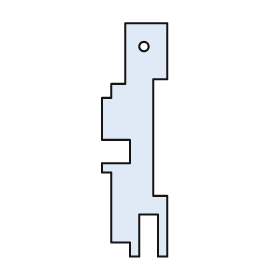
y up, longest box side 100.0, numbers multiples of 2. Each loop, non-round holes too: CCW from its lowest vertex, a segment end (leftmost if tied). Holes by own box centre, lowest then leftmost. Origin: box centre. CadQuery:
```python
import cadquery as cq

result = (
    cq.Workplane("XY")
    .moveTo(-2.0, -50.0)
    .lineTo(2.0, -50.0)
    .lineTo(2.0, -32.0)
    .lineTo(10.0, -32.0)
    .lineTo(10.0, -50.0)
    .lineTo(14.0, -50.0)
    .lineTo(14.0, -24.0)
    .lineTo(8.0, -24.0)
    .lineTo(8.0, 26.0)
    .lineTo(14.0, 26.0)
    .lineTo(14.0, 50.0)
    .lineTo(-4.0, 50.0)
    .lineTo(-4.0, 24.0)
    .lineTo(-10.0, 24.0)
    .lineTo(-10.0, 18.0)
    .lineTo(-14.0, 18.0)
    .lineTo(-14.0, 0.0)
    .lineTo(-2.0, 0.0)
    .lineTo(-2.0, -10.0)
    .lineTo(-14.0, -10.0)
    .lineTo(-14.0, -14.0)
    .lineTo(-10.0, -14.0)
    .lineTo(-10.0, -44.0)
    .lineTo(-2.0, -44.0)
    .close()
    .moveTo(4.0, 40.0)
    .circle(2.0)
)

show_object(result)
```